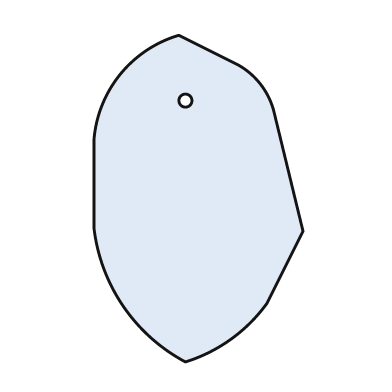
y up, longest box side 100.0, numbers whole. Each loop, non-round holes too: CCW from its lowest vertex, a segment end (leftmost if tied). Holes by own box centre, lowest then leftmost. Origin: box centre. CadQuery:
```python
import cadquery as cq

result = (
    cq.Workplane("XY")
    .moveTo(-4.0, -50.0)
    .threePointArc((10.0, -43.0), (21.0, -32.0))
    .lineTo(32.0, -10.0)
    .lineTo(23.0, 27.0)
    .threePointArc((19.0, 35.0), (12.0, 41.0))
    .lineTo(-6.0, 50.0)
    .threePointArc((-24.0, 38.0), (-32.0, 18.0))
    .lineTo(-32.0, -9.0)
    .threePointArc((-23.0, -33.0), (-4.0, -50.0))
    .close()
    .moveTo(-4.0, 30.0)
    .circle(2.0)
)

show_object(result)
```